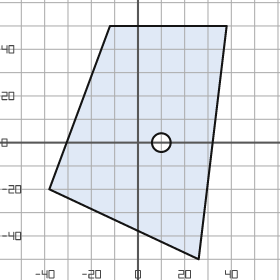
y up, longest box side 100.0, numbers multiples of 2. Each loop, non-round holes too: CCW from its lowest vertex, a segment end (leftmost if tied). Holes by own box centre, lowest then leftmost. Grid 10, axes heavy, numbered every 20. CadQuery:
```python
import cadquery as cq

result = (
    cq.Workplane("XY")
    .moveTo(26.0, -50.0)
    .lineTo(38.0, 50.0)
    .lineTo(-12.0, 50.0)
    .lineTo(-38.0, -20.0)
    .close()
    .moveTo(10.0, 0.0)
    .circle(4.0)
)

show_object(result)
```